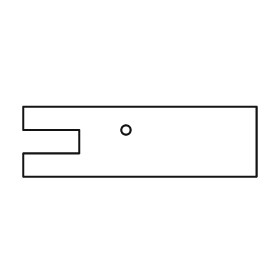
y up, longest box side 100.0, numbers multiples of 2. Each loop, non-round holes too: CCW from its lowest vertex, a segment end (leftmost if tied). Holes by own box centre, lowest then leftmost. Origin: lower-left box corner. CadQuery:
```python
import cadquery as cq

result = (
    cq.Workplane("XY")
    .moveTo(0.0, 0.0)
    .lineTo(100.0, 0.0)
    .lineTo(100.0, 30.0)
    .lineTo(0.0, 30.0)
    .lineTo(0.0, 20.0)
    .lineTo(24.0, 20.0)
    .lineTo(24.0, 10.0)
    .lineTo(0.0, 10.0)
    .close()
    .moveTo(44.0, 20.0)
    .circle(2.0)
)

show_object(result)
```